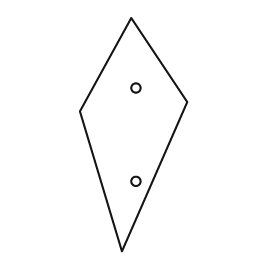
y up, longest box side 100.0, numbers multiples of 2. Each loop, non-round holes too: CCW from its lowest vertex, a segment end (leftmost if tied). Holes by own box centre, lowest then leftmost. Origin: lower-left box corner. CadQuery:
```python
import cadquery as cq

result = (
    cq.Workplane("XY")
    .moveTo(18.0, 0.0)
    .lineTo(46.0, 64.0)
    .lineTo(22.0, 100.0)
    .lineTo(0.0, 60.0)
    .close()
    .moveTo(24.0, 30.0)
    .circle(2.0)
    .moveTo(24.0, 70.0)
    .circle(2.0)
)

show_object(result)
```